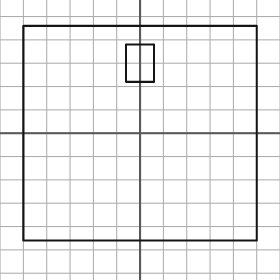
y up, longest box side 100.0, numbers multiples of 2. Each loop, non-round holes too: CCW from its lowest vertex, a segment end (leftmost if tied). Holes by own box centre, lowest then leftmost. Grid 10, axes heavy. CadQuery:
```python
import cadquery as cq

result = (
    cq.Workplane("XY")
    .moveTo(-50.0, -46.0)
    .lineTo(50.0, -46.0)
    .lineTo(50.0, 46.0)
    .lineTo(-50.0, 46.0)
    .close()
    .moveTo(-6.0, 22.0)
    .lineTo(6.0, 22.0)
    .lineTo(6.0, 38.0)
    .lineTo(-6.0, 38.0)
    .close()
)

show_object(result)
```